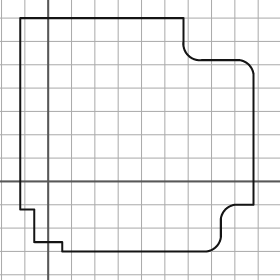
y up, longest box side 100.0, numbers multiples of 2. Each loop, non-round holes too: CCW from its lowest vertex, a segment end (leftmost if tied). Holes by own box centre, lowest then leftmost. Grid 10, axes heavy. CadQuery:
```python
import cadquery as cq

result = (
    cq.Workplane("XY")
    .moveTo(6.0, -30.0)
    .lineTo(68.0, -30.0)
    .threePointArc((72.0, -28.0), (74.0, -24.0))
    .lineTo(74.0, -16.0)
    .threePointArc((76.0, -12.0), (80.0, -10.0))
    .lineTo(88.0, -10.0)
    .lineTo(88.0, 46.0)
    .threePointArc((86.0, 50.0), (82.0, 52.0))
    .lineTo(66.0, 52.0)
    .threePointArc((60.0, 54.0), (58.0, 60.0))
    .lineTo(58.0, 70.0)
    .lineTo(-12.0, 70.0)
    .lineTo(-12.0, -12.0)
    .lineTo(-6.0, -12.0)
    .lineTo(-6.0, -26.0)
    .lineTo(6.0, -26.0)
    .close()
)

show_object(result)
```